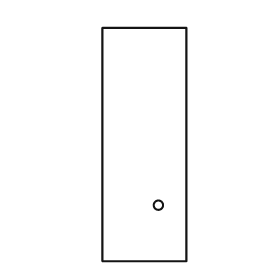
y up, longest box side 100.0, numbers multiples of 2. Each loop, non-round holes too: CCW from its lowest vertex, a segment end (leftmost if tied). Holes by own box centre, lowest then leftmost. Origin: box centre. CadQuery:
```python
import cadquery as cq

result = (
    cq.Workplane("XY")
    .moveTo(-18.0, -50.0)
    .lineTo(18.0, -50.0)
    .lineTo(18.0, 50.0)
    .lineTo(-18.0, 50.0)
    .close()
    .moveTo(6.0, -26.0)
    .circle(2.0)
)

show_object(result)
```